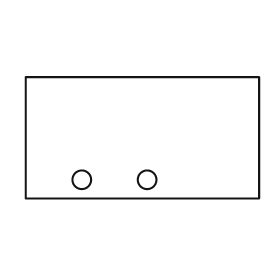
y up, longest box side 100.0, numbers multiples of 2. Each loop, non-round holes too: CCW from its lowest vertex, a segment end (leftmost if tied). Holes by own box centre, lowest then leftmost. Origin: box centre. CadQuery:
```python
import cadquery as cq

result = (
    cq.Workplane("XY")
    .moveTo(-50.0, -26.0)
    .lineTo(50.0, -26.0)
    .lineTo(50.0, 26.0)
    .lineTo(-50.0, 26.0)
    .close()
    .moveTo(-26.0, -18.0)
    .circle(4.0)
    .moveTo(2.0, -18.0)
    .circle(4.0)
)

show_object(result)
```